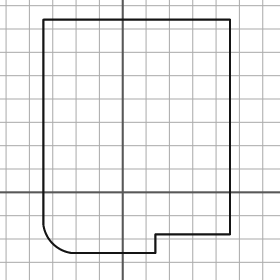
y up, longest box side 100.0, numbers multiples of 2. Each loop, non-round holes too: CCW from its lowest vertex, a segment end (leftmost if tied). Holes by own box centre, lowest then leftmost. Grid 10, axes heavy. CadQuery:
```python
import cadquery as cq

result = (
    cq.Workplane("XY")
    .moveTo(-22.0, -26.0)
    .lineTo(14.0, -26.0)
    .lineTo(14.0, -18.0)
    .lineTo(46.0, -18.0)
    .lineTo(46.0, 74.0)
    .lineTo(-34.0, 74.0)
    .lineTo(-34.0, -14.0)
    .threePointArc((-30.0, -22.0), (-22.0, -26.0))
    .close()
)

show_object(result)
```